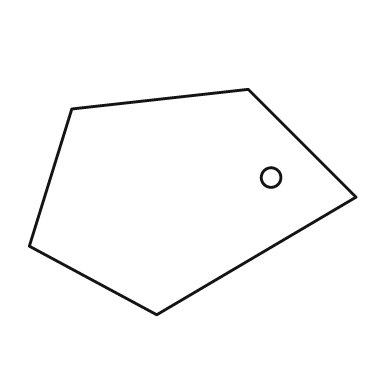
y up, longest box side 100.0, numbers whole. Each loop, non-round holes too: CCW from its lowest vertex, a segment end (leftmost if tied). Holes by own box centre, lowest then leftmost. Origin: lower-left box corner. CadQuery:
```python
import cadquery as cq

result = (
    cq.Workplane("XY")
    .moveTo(39.0, 0.0)
    .lineTo(100.0, 36.0)
    .lineTo(67.0, 69.0)
    .lineTo(13.0, 63.0)
    .lineTo(0.0, 21.0)
    .close()
    .moveTo(74.0, 42.0)
    .circle(3.0)
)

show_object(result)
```